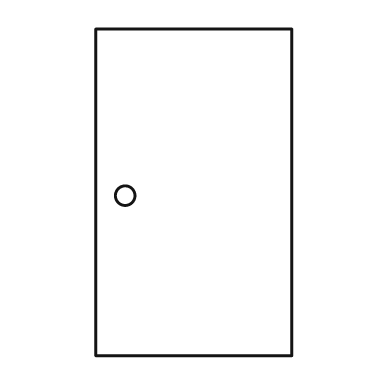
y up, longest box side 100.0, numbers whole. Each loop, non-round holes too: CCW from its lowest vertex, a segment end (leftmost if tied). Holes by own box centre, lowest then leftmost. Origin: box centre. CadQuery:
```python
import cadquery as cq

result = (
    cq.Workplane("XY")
    .moveTo(-30.0, -50.0)
    .lineTo(30.0, -50.0)
    .lineTo(30.0, 50.0)
    .lineTo(-30.0, 50.0)
    .close()
    .moveTo(-21.0, -1.0)
    .circle(3.0)
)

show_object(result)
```